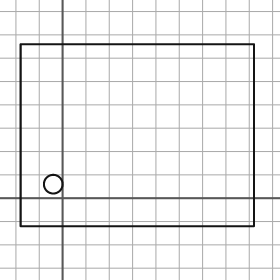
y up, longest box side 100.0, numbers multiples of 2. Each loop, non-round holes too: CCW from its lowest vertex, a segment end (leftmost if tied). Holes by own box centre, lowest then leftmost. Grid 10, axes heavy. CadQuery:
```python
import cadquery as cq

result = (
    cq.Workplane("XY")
    .moveTo(-18.0, -12.0)
    .lineTo(82.0, -12.0)
    .lineTo(82.0, 66.0)
    .lineTo(-18.0, 66.0)
    .close()
    .moveTo(-4.0, 6.0)
    .circle(4.0)
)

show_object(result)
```